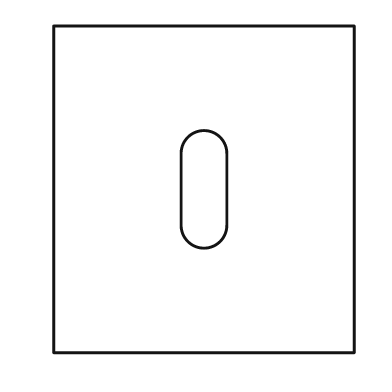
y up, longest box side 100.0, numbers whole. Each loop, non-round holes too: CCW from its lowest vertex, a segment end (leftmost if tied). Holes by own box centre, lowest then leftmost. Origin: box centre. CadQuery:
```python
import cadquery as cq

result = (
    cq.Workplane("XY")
    .moveTo(-46.0, -50.0)
    .lineTo(46.0, -50.0)
    .lineTo(46.0, 50.0)
    .lineTo(-46.0, 50.0)
    .close()
    .moveTo(-7.0, -11.0)
    .threePointArc((0.0, -18.0), (7.0, -11.0))
    .lineTo(7.0, 11.0)
    .threePointArc((0.0, 18.0), (-7.0, 11.0))
    .close()
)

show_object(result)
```